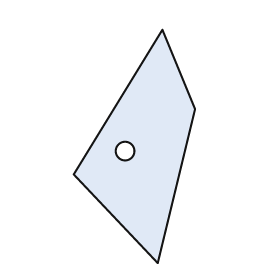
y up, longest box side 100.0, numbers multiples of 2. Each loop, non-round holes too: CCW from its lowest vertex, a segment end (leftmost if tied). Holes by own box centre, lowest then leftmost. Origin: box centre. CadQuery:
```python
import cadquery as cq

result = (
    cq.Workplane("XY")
    .moveTo(10.0, -50.0)
    .lineTo(26.0, 16.0)
    .lineTo(12.0, 50.0)
    .lineTo(-26.0, -12.0)
    .close()
    .moveTo(-4.0, -2.0)
    .circle(4.0)
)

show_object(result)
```